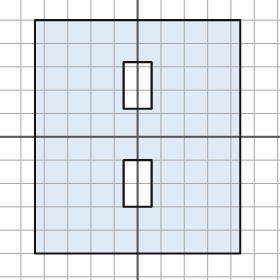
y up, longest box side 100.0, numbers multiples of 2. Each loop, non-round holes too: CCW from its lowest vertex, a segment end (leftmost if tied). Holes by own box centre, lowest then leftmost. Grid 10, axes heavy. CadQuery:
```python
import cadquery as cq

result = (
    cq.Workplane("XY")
    .moveTo(-44.0, -50.0)
    .lineTo(44.0, -50.0)
    .lineTo(44.0, 50.0)
    .lineTo(-44.0, 50.0)
    .close()
    .moveTo(-6.0, -30.0)
    .lineTo(6.0, -30.0)
    .lineTo(6.0, -10.0)
    .lineTo(-6.0, -10.0)
    .close()
    .moveTo(-6.0, 12.0)
    .lineTo(6.0, 12.0)
    .lineTo(6.0, 32.0)
    .lineTo(-6.0, 32.0)
    .close()
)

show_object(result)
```